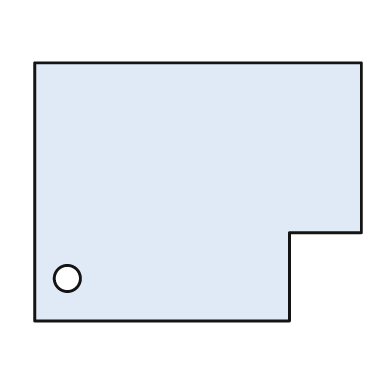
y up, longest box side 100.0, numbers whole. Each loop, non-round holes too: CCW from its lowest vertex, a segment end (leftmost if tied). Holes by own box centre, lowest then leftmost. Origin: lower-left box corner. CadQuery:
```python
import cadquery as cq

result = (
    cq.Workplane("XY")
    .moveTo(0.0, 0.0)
    .lineTo(78.0, 0.0)
    .lineTo(78.0, 27.0)
    .lineTo(100.0, 27.0)
    .lineTo(100.0, 79.0)
    .lineTo(0.0, 79.0)
    .close()
    .moveTo(10.0, 13.0)
    .circle(4.0)
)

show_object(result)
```